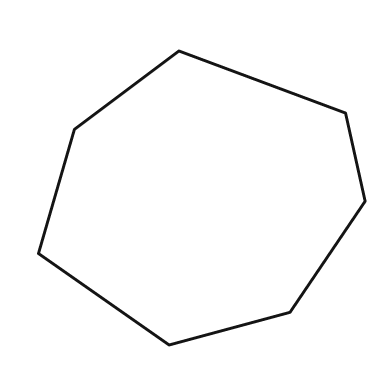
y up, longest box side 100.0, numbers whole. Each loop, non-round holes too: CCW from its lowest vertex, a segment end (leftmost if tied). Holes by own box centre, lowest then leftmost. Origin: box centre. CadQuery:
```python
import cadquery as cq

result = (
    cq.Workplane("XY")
    .moveTo(-10.0, -45.0)
    .lineTo(27.0, -35.0)
    .lineTo(50.0, -1.0)
    .lineTo(44.0, 26.0)
    .lineTo(-7.0, 45.0)
    .lineTo(-39.0, 21.0)
    .lineTo(-50.0, -17.0)
    .close()
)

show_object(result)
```